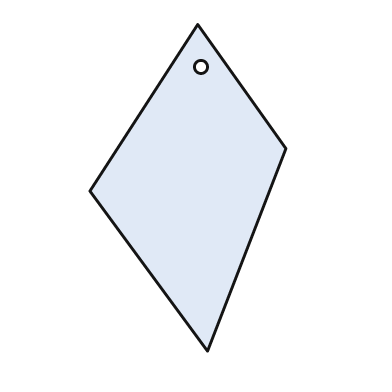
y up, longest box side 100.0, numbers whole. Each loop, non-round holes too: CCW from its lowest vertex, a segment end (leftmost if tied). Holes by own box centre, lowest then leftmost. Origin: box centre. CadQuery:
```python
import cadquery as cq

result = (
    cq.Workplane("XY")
    .moveTo(6.0, -50.0)
    .lineTo(30.0, 12.0)
    .lineTo(3.0, 50.0)
    .lineTo(-30.0, -1.0)
    .close()
    .moveTo(4.0, 37.0)
    .circle(2.0)
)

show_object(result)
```